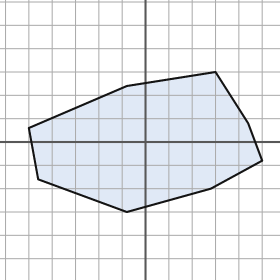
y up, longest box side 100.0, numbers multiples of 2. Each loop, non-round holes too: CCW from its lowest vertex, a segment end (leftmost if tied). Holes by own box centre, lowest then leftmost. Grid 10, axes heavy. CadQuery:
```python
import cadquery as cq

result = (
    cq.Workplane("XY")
    .moveTo(-8.0, -30.0)
    .lineTo(28.0, -20.0)
    .lineTo(50.0, -8.0)
    .lineTo(44.0, 8.0)
    .lineTo(30.0, 30.0)
    .lineTo(-8.0, 24.0)
    .lineTo(-50.0, 6.0)
    .lineTo(-46.0, -16.0)
    .close()
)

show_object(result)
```